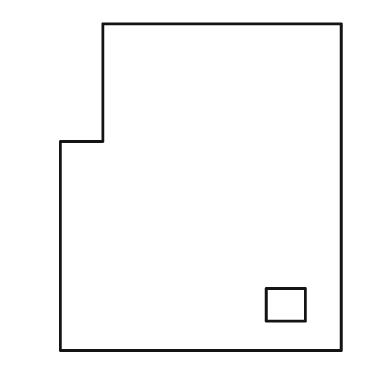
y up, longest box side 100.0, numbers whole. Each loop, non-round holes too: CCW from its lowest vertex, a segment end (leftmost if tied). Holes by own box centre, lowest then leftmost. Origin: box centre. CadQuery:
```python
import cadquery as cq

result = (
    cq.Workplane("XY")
    .moveTo(-43.0, -50.0)
    .lineTo(43.0, -50.0)
    .lineTo(43.0, 50.0)
    .lineTo(-30.0, 50.0)
    .lineTo(-30.0, 14.0)
    .lineTo(-43.0, 14.0)
    .close()
    .moveTo(20.0, -41.0)
    .lineTo(32.0, -41.0)
    .lineTo(32.0, -31.0)
    .lineTo(20.0, -31.0)
    .close()
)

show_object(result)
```